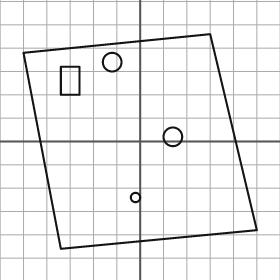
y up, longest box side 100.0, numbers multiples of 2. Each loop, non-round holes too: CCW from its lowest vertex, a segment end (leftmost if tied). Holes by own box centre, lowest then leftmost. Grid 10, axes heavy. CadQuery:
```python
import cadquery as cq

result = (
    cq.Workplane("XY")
    .moveTo(-34.0, -46.0)
    .lineTo(50.0, -38.0)
    .lineTo(30.0, 46.0)
    .lineTo(-50.0, 38.0)
    .close()
    .moveTo(-2.0, -24.0)
    .circle(2.0)
    .moveTo(14.0, 2.0)
    .circle(4.0)
    .moveTo(-34.0, 20.0)
    .lineTo(-26.0, 20.0)
    .lineTo(-26.0, 32.0)
    .lineTo(-34.0, 32.0)
    .close()
    .moveTo(-12.0, 34.0)
    .circle(4.0)
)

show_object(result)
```